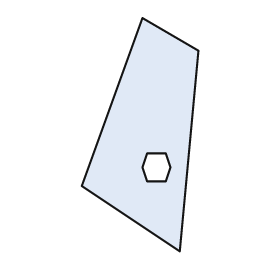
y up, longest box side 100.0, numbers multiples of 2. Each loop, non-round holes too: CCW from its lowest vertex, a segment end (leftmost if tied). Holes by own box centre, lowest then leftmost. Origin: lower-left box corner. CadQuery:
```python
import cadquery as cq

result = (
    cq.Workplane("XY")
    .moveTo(42.0, 0.0)
    .lineTo(50.0, 86.0)
    .lineTo(26.0, 100.0)
    .lineTo(0.0, 28.0)
    .close()
    .moveTo(28.0, 30.0)
    .lineTo(36.0, 30.0)
    .lineTo(38.0, 36.0)
    .lineTo(36.0, 42.0)
    .lineTo(28.0, 42.0)
    .lineTo(26.0, 36.0)
    .close()
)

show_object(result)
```